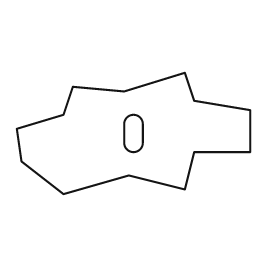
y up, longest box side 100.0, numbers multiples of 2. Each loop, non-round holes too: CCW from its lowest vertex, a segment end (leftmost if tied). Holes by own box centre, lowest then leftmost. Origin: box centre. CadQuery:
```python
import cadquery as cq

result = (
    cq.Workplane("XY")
    .moveTo(-30.0, -26.0)
    .lineTo(-2.0, -18.0)
    .lineTo(22.0, -24.0)
    .lineTo(26.0, -8.0)
    .lineTo(50.0, -8.0)
    .lineTo(50.0, 10.0)
    .lineTo(26.0, 14.0)
    .lineTo(22.0, 26.0)
    .lineTo(-4.0, 18.0)
    .lineTo(-26.0, 20.0)
    .lineTo(-30.0, 8.0)
    .lineTo(-50.0, 2.0)
    .lineTo(-48.0, -12.0)
    .close()
    .moveTo(-4.0, -4.0)
    .threePointArc((0.0, -8.0), (4.0, -4.0))
    .lineTo(4.0, 4.0)
    .threePointArc((0.0, 8.0), (-4.0, 4.0))
    .close()
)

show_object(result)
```